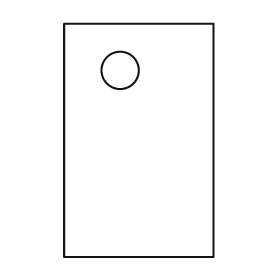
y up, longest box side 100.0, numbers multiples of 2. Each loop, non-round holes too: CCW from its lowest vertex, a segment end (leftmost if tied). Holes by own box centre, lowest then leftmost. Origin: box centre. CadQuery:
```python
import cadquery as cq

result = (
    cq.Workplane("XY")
    .moveTo(-32.0, -50.0)
    .lineTo(32.0, -50.0)
    .lineTo(32.0, 50.0)
    .lineTo(-32.0, 50.0)
    .close()
    .moveTo(-8.0, 30.0)
    .circle(8.0)
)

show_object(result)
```